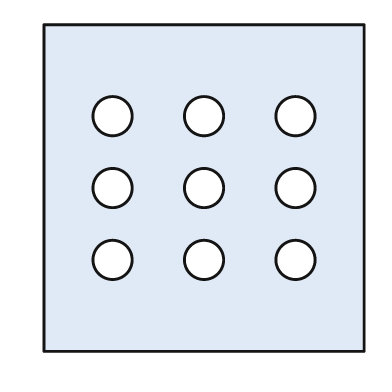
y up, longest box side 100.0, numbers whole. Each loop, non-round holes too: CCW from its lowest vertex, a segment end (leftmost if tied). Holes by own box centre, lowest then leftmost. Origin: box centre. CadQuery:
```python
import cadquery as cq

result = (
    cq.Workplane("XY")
    .moveTo(-49.0, -50.0)
    .lineTo(49.0, -50.0)
    .lineTo(49.0, 50.0)
    .lineTo(-49.0, 50.0)
    .close()
    .moveTo(-28.0, -22.0)
    .circle(6.0)
    .moveTo(0.0, -22.0)
    .circle(6.0)
    .moveTo(28.0, -22.0)
    .circle(6.0)
    .moveTo(-28.0, 0.0)
    .circle(6.0)
    .moveTo(0.0, 0.0)
    .circle(6.0)
    .moveTo(28.0, 0.0)
    .circle(6.0)
    .moveTo(-28.0, 22.0)
    .circle(6.0)
    .moveTo(0.0, 22.0)
    .circle(6.0)
    .moveTo(28.0, 22.0)
    .circle(6.0)
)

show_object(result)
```